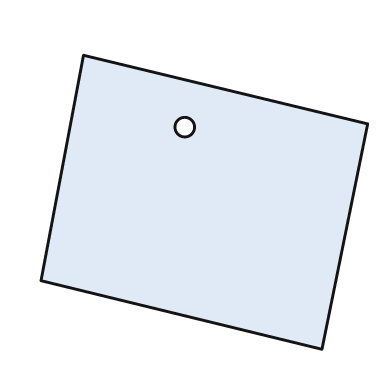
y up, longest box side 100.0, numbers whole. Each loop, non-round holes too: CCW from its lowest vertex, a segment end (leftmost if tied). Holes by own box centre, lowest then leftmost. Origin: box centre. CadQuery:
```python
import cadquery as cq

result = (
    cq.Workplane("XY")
    .moveTo(36.0, -45.0)
    .lineTo(50.0, 24.0)
    .lineTo(-37.0, 45.0)
    .lineTo(-50.0, -24.0)
    .close()
    .moveTo(-6.0, 23.0)
    .circle(3.0)
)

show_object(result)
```